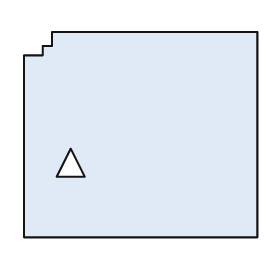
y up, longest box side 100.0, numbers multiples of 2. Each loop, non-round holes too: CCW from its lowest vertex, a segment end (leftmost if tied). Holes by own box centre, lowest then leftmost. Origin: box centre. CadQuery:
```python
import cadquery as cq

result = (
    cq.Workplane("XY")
    .moveTo(-50.0, -44.0)
    .lineTo(50.0, -44.0)
    .lineTo(50.0, 44.0)
    .lineTo(-38.0, 44.0)
    .lineTo(-38.0, 38.0)
    .lineTo(-42.0, 38.0)
    .lineTo(-42.0, 34.0)
    .lineTo(-50.0, 34.0)
    .close()
    .moveTo(-36.0, -18.0)
    .lineTo(-24.0, -18.0)
    .lineTo(-30.0, -6.0)
    .close()
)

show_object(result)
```